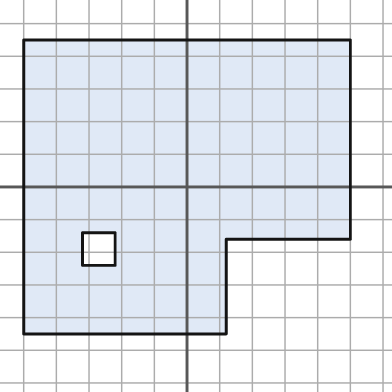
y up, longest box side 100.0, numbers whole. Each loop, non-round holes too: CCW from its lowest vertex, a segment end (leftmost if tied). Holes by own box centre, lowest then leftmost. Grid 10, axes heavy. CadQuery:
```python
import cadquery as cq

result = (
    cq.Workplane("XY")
    .moveTo(-50.0, -45.0)
    .lineTo(12.0, -45.0)
    .lineTo(12.0, -16.0)
    .lineTo(50.0, -16.0)
    .lineTo(50.0, 45.0)
    .lineTo(-50.0, 45.0)
    .close()
    .moveTo(-32.0, -24.0)
    .lineTo(-22.0, -24.0)
    .lineTo(-22.0, -14.0)
    .lineTo(-32.0, -14.0)
    .close()
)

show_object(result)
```